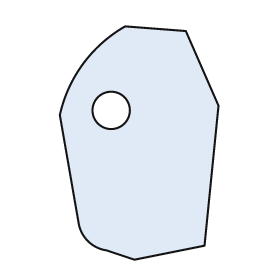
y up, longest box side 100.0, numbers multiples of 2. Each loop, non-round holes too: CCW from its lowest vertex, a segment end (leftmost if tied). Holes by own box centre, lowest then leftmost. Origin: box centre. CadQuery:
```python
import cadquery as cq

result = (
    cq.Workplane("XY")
    .moveTo(-2.0, -50.0)
    .lineTo(28.0, -44.0)
    .lineTo(34.0, 16.0)
    .lineTo(20.0, 48.0)
    .lineTo(-6.0, 50.0)
    .threePointArc((-24.0, 34.0), (-34.0, 12.0))
    .lineTo(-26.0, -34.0)
    .threePointArc((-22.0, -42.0), (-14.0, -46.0))
    .close()
    .moveTo(-12.0, 14.0)
    .circle(8.0)
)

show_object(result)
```